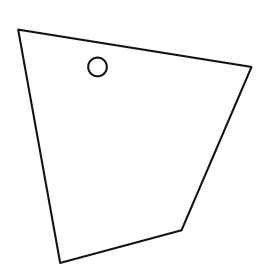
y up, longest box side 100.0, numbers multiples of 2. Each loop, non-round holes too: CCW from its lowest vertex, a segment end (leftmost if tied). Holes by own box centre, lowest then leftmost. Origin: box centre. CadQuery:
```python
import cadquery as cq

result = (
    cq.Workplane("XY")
    .moveTo(-32.0, -50.0)
    .lineTo(20.0, -36.0)
    .lineTo(50.0, 34.0)
    .lineTo(-50.0, 50.0)
    .close()
    .moveTo(-16.0, 34.0)
    .circle(4.0)
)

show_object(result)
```